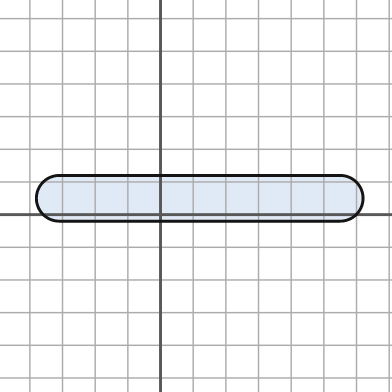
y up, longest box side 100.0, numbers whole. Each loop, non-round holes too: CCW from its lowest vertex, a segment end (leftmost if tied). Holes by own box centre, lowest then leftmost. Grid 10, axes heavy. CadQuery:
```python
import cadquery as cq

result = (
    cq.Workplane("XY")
    .moveTo(-31.0, -2.0)
    .lineTo(55.0, -2.0)
    .threePointArc((62.0, 5.0), (55.0, 12.0))
    .lineTo(-31.0, 12.0)
    .threePointArc((-38.0, 5.0), (-31.0, -2.0))
    .close()
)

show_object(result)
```